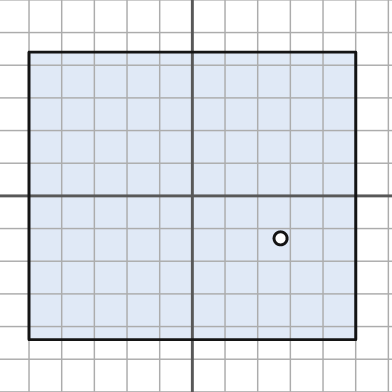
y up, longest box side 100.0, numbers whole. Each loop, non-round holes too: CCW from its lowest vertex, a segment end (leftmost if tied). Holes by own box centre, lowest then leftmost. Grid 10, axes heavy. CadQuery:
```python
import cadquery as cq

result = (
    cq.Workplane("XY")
    .moveTo(-50.0, -44.0)
    .lineTo(50.0, -44.0)
    .lineTo(50.0, 44.0)
    .lineTo(-50.0, 44.0)
    .close()
    .moveTo(27.0, -13.0)
    .circle(2.0)
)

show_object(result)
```